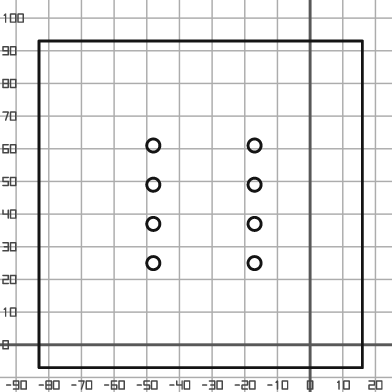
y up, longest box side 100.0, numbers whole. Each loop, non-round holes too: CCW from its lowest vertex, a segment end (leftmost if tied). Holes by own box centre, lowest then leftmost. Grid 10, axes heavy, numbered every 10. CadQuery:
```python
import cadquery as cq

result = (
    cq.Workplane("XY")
    .moveTo(-83.0, -7.0)
    .lineTo(16.0, -7.0)
    .lineTo(16.0, 93.0)
    .lineTo(-83.0, 93.0)
    .close()
    .moveTo(-48.0, 25.0)
    .circle(2.0)
    .moveTo(-17.0, 25.0)
    .circle(2.0)
    .moveTo(-48.0, 37.0)
    .circle(2.0)
    .moveTo(-17.0, 37.0)
    .circle(2.0)
    .moveTo(-48.0, 49.0)
    .circle(2.0)
    .moveTo(-17.0, 49.0)
    .circle(2.0)
    .moveTo(-48.0, 61.0)
    .circle(2.0)
    .moveTo(-17.0, 61.0)
    .circle(2.0)
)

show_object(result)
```